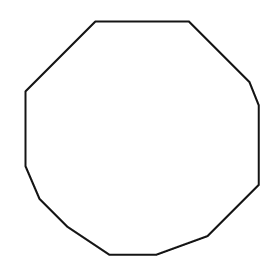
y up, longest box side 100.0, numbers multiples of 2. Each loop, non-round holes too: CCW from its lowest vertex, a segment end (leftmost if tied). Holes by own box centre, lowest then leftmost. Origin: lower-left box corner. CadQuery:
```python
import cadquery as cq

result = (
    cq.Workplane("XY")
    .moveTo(36.0, 0.0)
    .lineTo(56.0, 0.0)
    .lineTo(78.0, 8.0)
    .lineTo(100.0, 30.0)
    .lineTo(100.0, 64.0)
    .lineTo(96.0, 74.0)
    .lineTo(70.0, 100.0)
    .lineTo(30.0, 100.0)
    .lineTo(0.0, 70.0)
    .lineTo(0.0, 38.0)
    .lineTo(6.0, 24.0)
    .lineTo(18.0, 12.0)
    .close()
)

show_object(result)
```